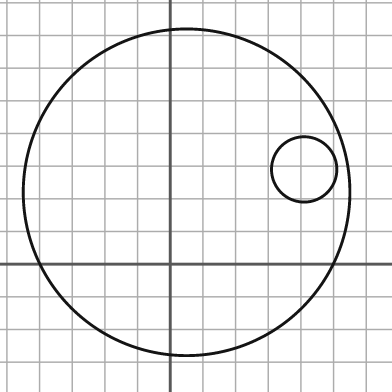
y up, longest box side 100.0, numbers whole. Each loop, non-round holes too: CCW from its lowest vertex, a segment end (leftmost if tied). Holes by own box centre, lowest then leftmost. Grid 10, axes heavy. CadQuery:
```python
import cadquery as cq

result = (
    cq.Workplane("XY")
    .moveTo(5.0, 22.0)
    .circle(50.0)
    .moveTo(41.0, 29.0)
    .circle(10.0)
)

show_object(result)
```